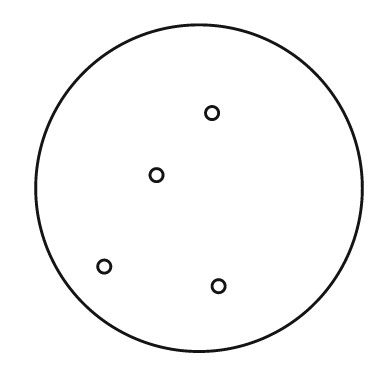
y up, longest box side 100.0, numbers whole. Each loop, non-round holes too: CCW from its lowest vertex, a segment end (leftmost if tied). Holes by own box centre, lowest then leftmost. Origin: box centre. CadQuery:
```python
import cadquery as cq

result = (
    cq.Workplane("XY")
    .moveTo(0.0, 0.0)
    .circle(50.0)
    .moveTo(6.0, -30.0)
    .circle(2.0)
    .moveTo(-29.0, -24.0)
    .circle(2.0)
    .moveTo(-13.0, 4.0)
    .circle(2.0)
    .moveTo(4.0, 23.0)
    .circle(2.0)
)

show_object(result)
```